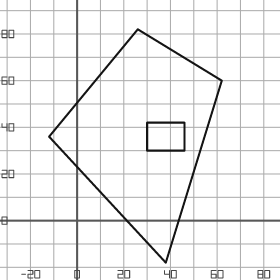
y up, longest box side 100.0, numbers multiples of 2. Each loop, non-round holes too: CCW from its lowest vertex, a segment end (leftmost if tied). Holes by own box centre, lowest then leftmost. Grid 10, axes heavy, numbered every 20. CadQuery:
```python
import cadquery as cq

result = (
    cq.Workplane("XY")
    .moveTo(38.0, -18.0)
    .lineTo(62.0, 60.0)
    .lineTo(26.0, 82.0)
    .lineTo(-12.0, 36.0)
    .close()
    .moveTo(30.0, 30.0)
    .lineTo(46.0, 30.0)
    .lineTo(46.0, 42.0)
    .lineTo(30.0, 42.0)
    .close()
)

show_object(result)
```